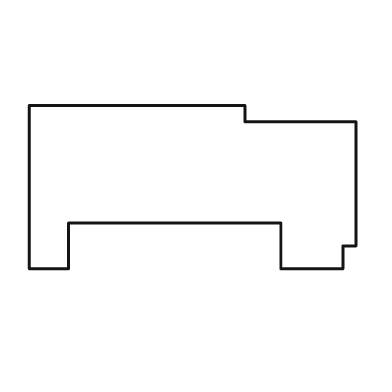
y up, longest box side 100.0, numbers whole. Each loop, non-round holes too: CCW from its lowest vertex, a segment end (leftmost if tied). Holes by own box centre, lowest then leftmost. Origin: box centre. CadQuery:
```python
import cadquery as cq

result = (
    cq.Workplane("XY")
    .moveTo(-50.0, -25.0)
    .lineTo(-38.0, -25.0)
    .lineTo(-38.0, -11.0)
    .lineTo(27.0, -11.0)
    .lineTo(27.0, -25.0)
    .lineTo(46.0, -25.0)
    .lineTo(46.0, -18.0)
    .lineTo(50.0, -18.0)
    .lineTo(50.0, 20.0)
    .lineTo(16.0, 20.0)
    .lineTo(16.0, 25.0)
    .lineTo(-50.0, 25.0)
    .close()
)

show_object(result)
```